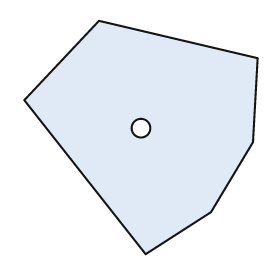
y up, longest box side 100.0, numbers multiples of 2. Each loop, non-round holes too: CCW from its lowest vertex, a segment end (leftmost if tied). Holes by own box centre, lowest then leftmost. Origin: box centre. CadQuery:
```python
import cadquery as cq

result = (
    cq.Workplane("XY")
    .moveTo(2.0, -50.0)
    .lineTo(30.0, -32.0)
    .lineTo(48.0, -2.0)
    .lineTo(50.0, 34.0)
    .lineTo(-18.0, 50.0)
    .lineTo(-50.0, 16.0)
    .close()
    .moveTo(0.0, 4.0)
    .circle(4.0)
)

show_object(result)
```